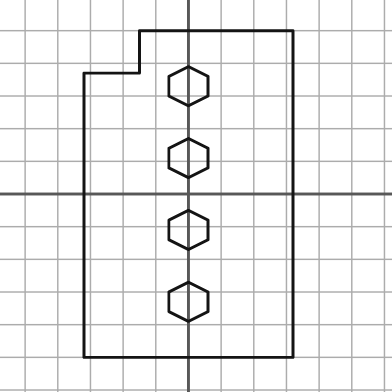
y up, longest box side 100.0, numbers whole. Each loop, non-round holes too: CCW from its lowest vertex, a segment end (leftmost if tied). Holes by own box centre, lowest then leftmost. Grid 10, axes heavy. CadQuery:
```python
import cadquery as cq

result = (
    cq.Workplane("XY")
    .moveTo(-32.0, -50.0)
    .lineTo(32.0, -50.0)
    .lineTo(32.0, 50.0)
    .lineTo(-15.0, 50.0)
    .lineTo(-15.0, 37.0)
    .lineTo(-32.0, 37.0)
    .close()
    .moveTo(0.0, -39.0)
    .lineTo(6.0, -36.0)
    .lineTo(6.0, -30.0)
    .lineTo(0.0, -27.0)
    .lineTo(-6.0, -30.0)
    .lineTo(-6.0, -36.0)
    .close()
    .moveTo(0.0, -17.0)
    .lineTo(6.0, -14.0)
    .lineTo(6.0, -8.0)
    .lineTo(0.0, -5.0)
    .lineTo(-6.0, -8.0)
    .lineTo(-6.0, -14.0)
    .close()
    .moveTo(0.0, 5.0)
    .lineTo(6.0, 8.0)
    .lineTo(6.0, 14.0)
    .lineTo(0.0, 17.0)
    .lineTo(-6.0, 14.0)
    .lineTo(-6.0, 8.0)
    .close()
    .moveTo(0.0, 27.0)
    .lineTo(6.0, 30.0)
    .lineTo(6.0, 36.0)
    .lineTo(0.0, 39.0)
    .lineTo(-6.0, 36.0)
    .lineTo(-6.0, 30.0)
    .close()
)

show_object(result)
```